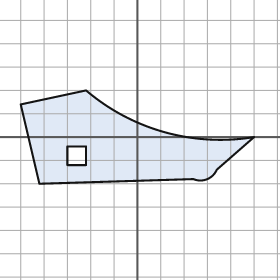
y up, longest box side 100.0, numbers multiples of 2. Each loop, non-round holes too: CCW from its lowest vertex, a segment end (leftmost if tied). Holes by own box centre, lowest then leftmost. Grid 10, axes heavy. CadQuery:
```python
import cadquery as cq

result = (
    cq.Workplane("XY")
    .moveTo(-42.0, -20.0)
    .lineTo(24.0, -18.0)
    .threePointArc((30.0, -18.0), (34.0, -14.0))
    .lineTo(50.0, 0.0)
    .threePointArc((12.0, 2.0), (-22.0, 20.0))
    .lineTo(-50.0, 14.0)
    .close()
    .moveTo(-30.0, -12.0)
    .lineTo(-22.0, -12.0)
    .lineTo(-22.0, -4.0)
    .lineTo(-30.0, -4.0)
    .close()
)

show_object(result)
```